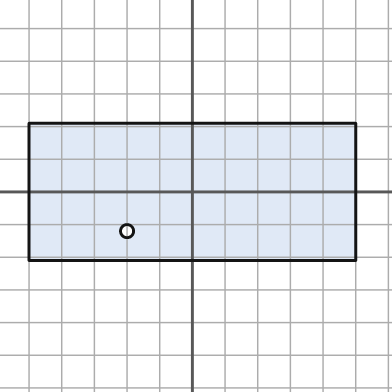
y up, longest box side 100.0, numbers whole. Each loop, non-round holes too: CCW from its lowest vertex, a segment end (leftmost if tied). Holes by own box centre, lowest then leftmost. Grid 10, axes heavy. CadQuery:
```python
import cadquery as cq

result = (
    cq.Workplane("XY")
    .moveTo(-50.0, -21.0)
    .lineTo(50.0, -21.0)
    .lineTo(50.0, 21.0)
    .lineTo(-50.0, 21.0)
    .close()
    .moveTo(-20.0, -12.0)
    .circle(2.0)
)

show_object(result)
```